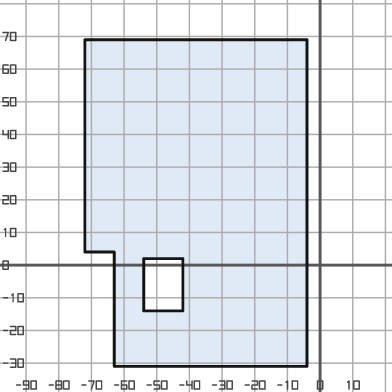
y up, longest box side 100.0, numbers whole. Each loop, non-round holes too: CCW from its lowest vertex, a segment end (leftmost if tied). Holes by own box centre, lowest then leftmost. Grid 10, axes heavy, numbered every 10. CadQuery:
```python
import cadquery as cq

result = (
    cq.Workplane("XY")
    .moveTo(-63.0, -31.0)
    .lineTo(-4.0, -31.0)
    .lineTo(-4.0, 69.0)
    .lineTo(-72.0, 69.0)
    .lineTo(-72.0, 4.0)
    .lineTo(-63.0, 4.0)
    .close()
    .moveTo(-54.0, -14.0)
    .lineTo(-42.0, -14.0)
    .lineTo(-42.0, 2.0)
    .lineTo(-54.0, 2.0)
    .close()
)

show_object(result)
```